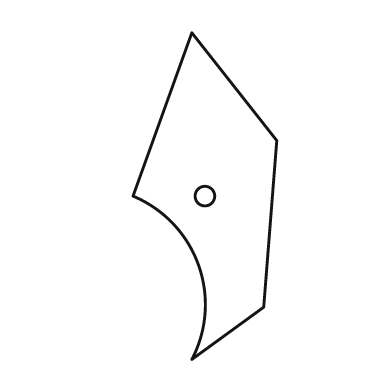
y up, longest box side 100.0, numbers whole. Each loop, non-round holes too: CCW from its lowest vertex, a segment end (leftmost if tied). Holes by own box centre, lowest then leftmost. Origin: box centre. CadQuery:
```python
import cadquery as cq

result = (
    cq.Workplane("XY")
    .moveTo(-4.0, -50.0)
    .lineTo(18.0, -34.0)
    .lineTo(22.0, 17.0)
    .lineTo(-4.0, 50.0)
    .lineTo(-22.0, 0.0)
    .threePointArc((-2.0, -21.0), (-4.0, -50.0))
    .close()
    .moveTo(0.0, 0.0)
    .circle(3.0)
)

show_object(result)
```